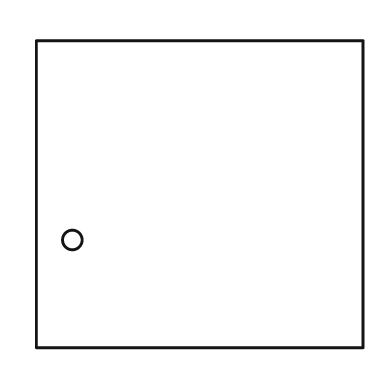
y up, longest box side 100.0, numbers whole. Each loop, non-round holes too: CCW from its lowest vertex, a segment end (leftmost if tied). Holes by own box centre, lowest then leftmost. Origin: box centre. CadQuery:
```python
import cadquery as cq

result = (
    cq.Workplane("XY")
    .moveTo(-50.0, -47.0)
    .lineTo(50.0, -47.0)
    .lineTo(50.0, 47.0)
    .lineTo(-50.0, 47.0)
    .close()
    .moveTo(-39.0, -14.0)
    .circle(3.0)
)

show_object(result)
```